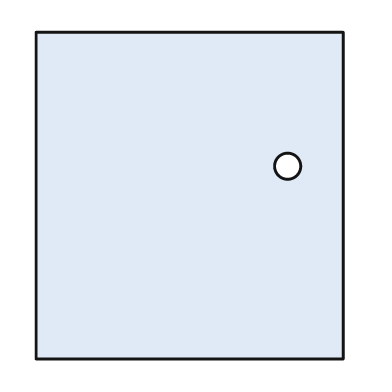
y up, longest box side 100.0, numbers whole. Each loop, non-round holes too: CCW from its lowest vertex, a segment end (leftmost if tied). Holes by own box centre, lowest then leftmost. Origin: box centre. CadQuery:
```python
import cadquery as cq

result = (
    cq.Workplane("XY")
    .moveTo(-47.0, -50.0)
    .lineTo(47.0, -50.0)
    .lineTo(47.0, 50.0)
    .lineTo(-47.0, 50.0)
    .close()
    .moveTo(30.0, 9.0)
    .circle(4.0)
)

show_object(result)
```